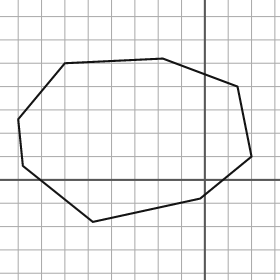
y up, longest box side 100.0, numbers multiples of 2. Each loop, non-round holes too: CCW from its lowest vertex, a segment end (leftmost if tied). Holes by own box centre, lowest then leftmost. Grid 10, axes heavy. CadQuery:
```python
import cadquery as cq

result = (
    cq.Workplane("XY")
    .moveTo(-48.0, -18.0)
    .lineTo(-2.0, -8.0)
    .lineTo(20.0, 10.0)
    .lineTo(14.0, 40.0)
    .lineTo(-18.0, 52.0)
    .lineTo(-60.0, 50.0)
    .lineTo(-80.0, 26.0)
    .lineTo(-78.0, 6.0)
    .close()
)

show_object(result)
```